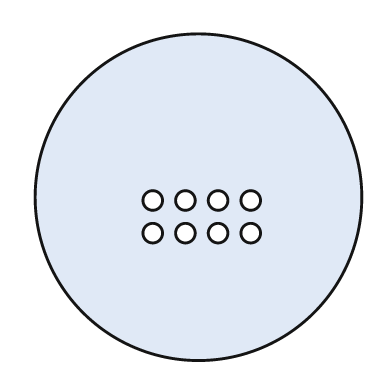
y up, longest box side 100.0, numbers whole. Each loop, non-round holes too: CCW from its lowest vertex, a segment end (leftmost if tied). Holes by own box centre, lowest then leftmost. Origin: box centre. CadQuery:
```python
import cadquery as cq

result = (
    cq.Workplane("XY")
    .moveTo(0.0, 0.0)
    .circle(50.0)
    .moveTo(-14.0, -11.0)
    .circle(3.0)
    .moveTo(-4.0, -11.0)
    .circle(3.0)
    .moveTo(6.0, -11.0)
    .circle(3.0)
    .moveTo(16.0, -11.0)
    .circle(3.0)
    .moveTo(-14.0, -1.0)
    .circle(3.0)
    .moveTo(-4.0, -1.0)
    .circle(3.0)
    .moveTo(6.0, -1.0)
    .circle(3.0)
    .moveTo(16.0, -1.0)
    .circle(3.0)
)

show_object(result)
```